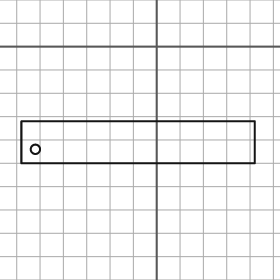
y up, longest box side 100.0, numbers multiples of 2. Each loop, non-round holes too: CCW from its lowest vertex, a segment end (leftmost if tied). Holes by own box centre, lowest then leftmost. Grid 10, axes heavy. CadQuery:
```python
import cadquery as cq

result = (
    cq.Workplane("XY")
    .moveTo(-58.0, -50.0)
    .lineTo(42.0, -50.0)
    .lineTo(42.0, -32.0)
    .lineTo(-58.0, -32.0)
    .close()
    .moveTo(-52.0, -44.0)
    .circle(2.0)
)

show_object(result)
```